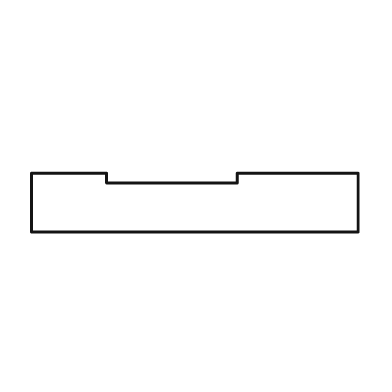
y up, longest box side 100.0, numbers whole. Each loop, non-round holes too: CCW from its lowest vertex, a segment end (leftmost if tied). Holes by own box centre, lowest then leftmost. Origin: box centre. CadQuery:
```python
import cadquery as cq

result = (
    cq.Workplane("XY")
    .moveTo(-50.0, -9.0)
    .lineTo(50.0, -9.0)
    .lineTo(50.0, 9.0)
    .lineTo(13.0, 9.0)
    .lineTo(13.0, 6.0)
    .lineTo(-27.0, 6.0)
    .lineTo(-27.0, 9.0)
    .lineTo(-50.0, 9.0)
    .close()
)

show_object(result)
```